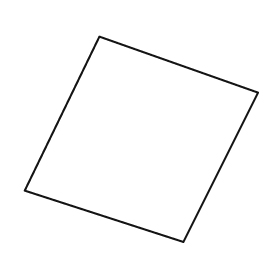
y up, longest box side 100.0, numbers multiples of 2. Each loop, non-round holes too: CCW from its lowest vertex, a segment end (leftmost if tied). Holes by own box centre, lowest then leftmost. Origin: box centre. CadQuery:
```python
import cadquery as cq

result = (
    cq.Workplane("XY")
    .moveTo(18.0, -44.0)
    .lineTo(50.0, 20.0)
    .lineTo(-18.0, 44.0)
    .lineTo(-50.0, -22.0)
    .close()
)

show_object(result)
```